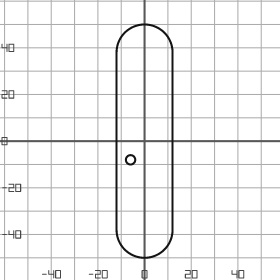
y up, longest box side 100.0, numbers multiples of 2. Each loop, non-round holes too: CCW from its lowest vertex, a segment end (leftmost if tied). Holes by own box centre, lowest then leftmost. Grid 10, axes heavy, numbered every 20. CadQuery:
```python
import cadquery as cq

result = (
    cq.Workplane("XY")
    .moveTo(-12.0, -38.0)
    .threePointArc((0.0, -50.0), (12.0, -38.0))
    .lineTo(12.0, 38.0)
    .threePointArc((0.0, 50.0), (-12.0, 38.0))
    .close()
    .moveTo(-6.0, -8.0)
    .circle(2.0)
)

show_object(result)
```